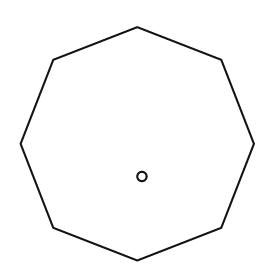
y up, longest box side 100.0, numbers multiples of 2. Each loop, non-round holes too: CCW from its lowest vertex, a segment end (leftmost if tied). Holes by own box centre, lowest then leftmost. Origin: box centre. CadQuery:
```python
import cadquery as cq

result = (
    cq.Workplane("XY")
    .moveTo(0.0, -50.0)
    .lineTo(36.0, -36.0)
    .lineTo(50.0, 0.0)
    .lineTo(36.0, 36.0)
    .lineTo(0.0, 50.0)
    .lineTo(-36.0, 36.0)
    .lineTo(-50.0, 0.0)
    .lineTo(-36.0, -36.0)
    .close()
    .moveTo(2.0, -14.0)
    .circle(2.0)
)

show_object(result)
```